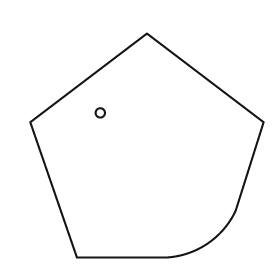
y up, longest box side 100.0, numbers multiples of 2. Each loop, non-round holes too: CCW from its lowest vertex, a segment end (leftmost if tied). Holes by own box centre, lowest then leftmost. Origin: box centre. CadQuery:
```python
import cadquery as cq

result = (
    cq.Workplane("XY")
    .moveTo(-30.0, -48.0)
    .lineTo(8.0, -48.0)
    .threePointArc((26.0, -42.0), (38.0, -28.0))
    .lineTo(50.0, 10.0)
    .lineTo(0.0, 48.0)
    .lineTo(-50.0, 10.0)
    .close()
    .moveTo(-20.0, 14.0)
    .circle(2.0)
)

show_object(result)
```